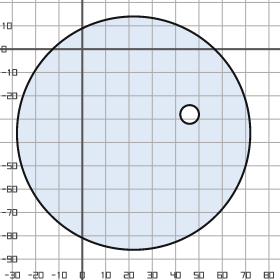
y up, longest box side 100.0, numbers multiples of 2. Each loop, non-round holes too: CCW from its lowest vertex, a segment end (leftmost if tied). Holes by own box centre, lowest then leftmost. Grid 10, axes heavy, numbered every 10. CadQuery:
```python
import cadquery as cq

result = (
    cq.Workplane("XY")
    .moveTo(22.0, -36.0)
    .circle(50.0)
    .moveTo(46.0, -28.0)
    .circle(4.0)
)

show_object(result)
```